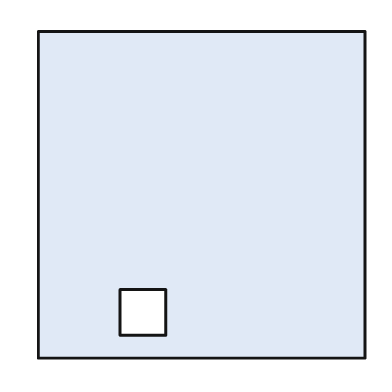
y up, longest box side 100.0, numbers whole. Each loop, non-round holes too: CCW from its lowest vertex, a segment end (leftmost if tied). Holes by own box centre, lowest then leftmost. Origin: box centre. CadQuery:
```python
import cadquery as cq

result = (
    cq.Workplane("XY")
    .moveTo(-50.0, -50.0)
    .lineTo(50.0, -50.0)
    .lineTo(50.0, 50.0)
    .lineTo(-50.0, 50.0)
    .close()
    .moveTo(-25.0, -43.0)
    .lineTo(-11.0, -43.0)
    .lineTo(-11.0, -29.0)
    .lineTo(-25.0, -29.0)
    .close()
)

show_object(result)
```